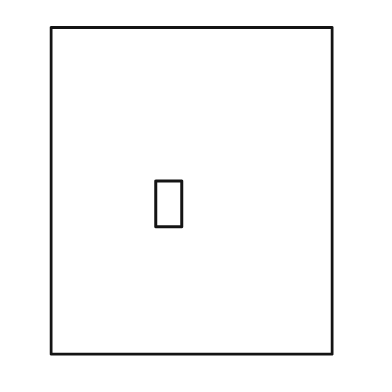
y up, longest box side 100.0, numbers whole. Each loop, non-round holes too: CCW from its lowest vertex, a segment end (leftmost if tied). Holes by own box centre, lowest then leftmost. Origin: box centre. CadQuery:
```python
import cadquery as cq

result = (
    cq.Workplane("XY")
    .moveTo(-43.0, -50.0)
    .lineTo(43.0, -50.0)
    .lineTo(43.0, 50.0)
    .lineTo(-43.0, 50.0)
    .close()
    .moveTo(-11.0, -11.0)
    .lineTo(-3.0, -11.0)
    .lineTo(-3.0, 3.0)
    .lineTo(-11.0, 3.0)
    .close()
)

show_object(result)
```